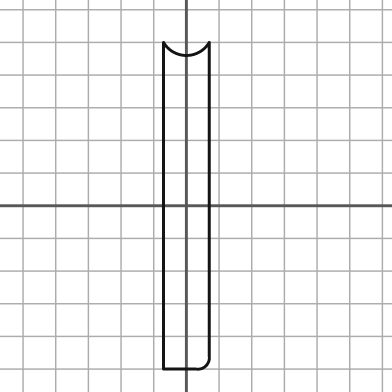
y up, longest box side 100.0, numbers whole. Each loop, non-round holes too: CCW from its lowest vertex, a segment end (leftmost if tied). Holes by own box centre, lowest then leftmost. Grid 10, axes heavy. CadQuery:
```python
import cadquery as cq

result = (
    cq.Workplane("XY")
    .moveTo(-7.0, -50.0)
    .lineTo(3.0, -50.0)
    .threePointArc((6.0, -49.0), (7.0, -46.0))
    .lineTo(7.0, 50.0)
    .threePointArc((0.0, 46.0), (-7.0, 50.0))
    .close()
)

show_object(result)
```